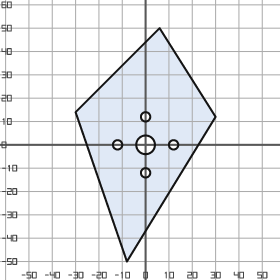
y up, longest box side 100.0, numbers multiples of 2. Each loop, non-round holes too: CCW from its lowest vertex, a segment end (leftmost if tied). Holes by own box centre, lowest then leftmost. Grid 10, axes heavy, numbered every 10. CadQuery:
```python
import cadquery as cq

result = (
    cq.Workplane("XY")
    .moveTo(-8.0, -50.0)
    .lineTo(30.0, 12.0)
    .lineTo(6.0, 50.0)
    .lineTo(-30.0, 14.0)
    .close()
    .moveTo(0.0, -12.0)
    .circle(2.0)
    .moveTo(-12.0, 0.0)
    .circle(2.0)
    .moveTo(0.0, 0.0)
    .circle(4.0)
    .moveTo(12.0, 0.0)
    .circle(2.0)
    .moveTo(0.0, 12.0)
    .circle(2.0)
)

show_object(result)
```